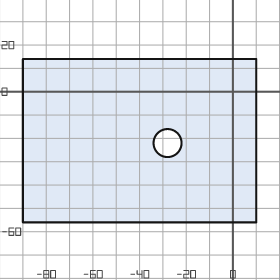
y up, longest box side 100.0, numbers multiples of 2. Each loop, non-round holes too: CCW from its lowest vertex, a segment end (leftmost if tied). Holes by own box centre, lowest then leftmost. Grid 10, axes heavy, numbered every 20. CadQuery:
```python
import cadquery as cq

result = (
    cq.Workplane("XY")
    .moveTo(-90.0, -56.0)
    .lineTo(10.0, -56.0)
    .lineTo(10.0, 14.0)
    .lineTo(-90.0, 14.0)
    .close()
    .moveTo(-28.0, -22.0)
    .circle(6.0)
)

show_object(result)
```